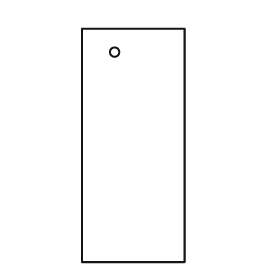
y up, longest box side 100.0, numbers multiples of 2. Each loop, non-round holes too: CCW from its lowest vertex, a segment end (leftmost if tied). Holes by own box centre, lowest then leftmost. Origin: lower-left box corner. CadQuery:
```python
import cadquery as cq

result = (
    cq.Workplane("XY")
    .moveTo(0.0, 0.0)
    .lineTo(44.0, 0.0)
    .lineTo(44.0, 100.0)
    .lineTo(0.0, 100.0)
    .close()
    .moveTo(14.0, 90.0)
    .circle(2.0)
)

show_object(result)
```